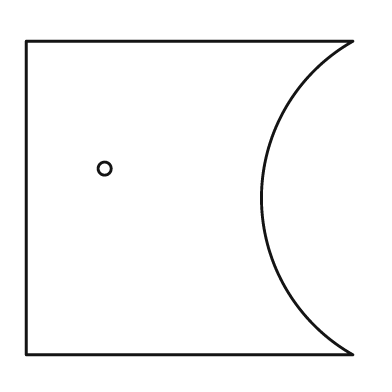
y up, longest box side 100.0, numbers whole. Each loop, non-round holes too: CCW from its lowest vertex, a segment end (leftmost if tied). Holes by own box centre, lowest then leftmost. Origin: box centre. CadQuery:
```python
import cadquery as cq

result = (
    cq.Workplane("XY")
    .moveTo(-50.0, -48.0)
    .lineTo(50.0, -48.0)
    .threePointArc((22.0, 0.0), (50.0, 48.0))
    .lineTo(-50.0, 48.0)
    .close()
    .moveTo(-26.0, 9.0)
    .circle(2.0)
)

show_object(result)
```